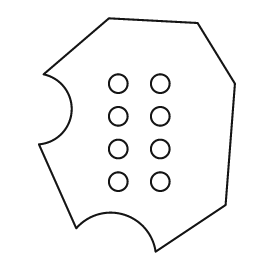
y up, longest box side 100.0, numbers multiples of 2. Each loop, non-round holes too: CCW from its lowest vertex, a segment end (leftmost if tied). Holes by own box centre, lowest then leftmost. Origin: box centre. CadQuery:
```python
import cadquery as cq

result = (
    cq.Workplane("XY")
    .moveTo(8.0, -50.0)
    .lineTo(38.0, -30.0)
    .lineTo(42.0, 22.0)
    .lineTo(26.0, 48.0)
    .lineTo(-12.0, 50.0)
    .lineTo(-40.0, 26.0)
    .threePointArc((-28.0, 10.0), (-42.0, -4.0))
    .lineTo(-26.0, -40.0)
    .threePointArc((-6.0, -34.0), (8.0, -50.0))
    .close()
    .moveTo(-8.0, -20.0)
    .circle(4.0)
    .moveTo(10.0, -20.0)
    .circle(4.0)
    .moveTo(-8.0, -6.0)
    .circle(4.0)
    .moveTo(10.0, -6.0)
    .circle(4.0)
    .moveTo(-8.0, 8.0)
    .circle(4.0)
    .moveTo(10.0, 8.0)
    .circle(4.0)
    .moveTo(-8.0, 22.0)
    .circle(4.0)
    .moveTo(10.0, 22.0)
    .circle(4.0)
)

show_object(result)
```